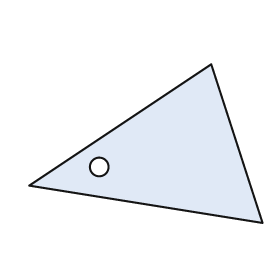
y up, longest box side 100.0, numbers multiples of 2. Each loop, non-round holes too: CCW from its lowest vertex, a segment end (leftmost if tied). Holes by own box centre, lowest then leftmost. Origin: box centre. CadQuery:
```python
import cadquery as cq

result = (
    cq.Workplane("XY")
    .moveTo(50.0, -34.0)
    .lineTo(28.0, 34.0)
    .lineTo(-50.0, -18.0)
    .close()
    .moveTo(-20.0, -10.0)
    .circle(4.0)
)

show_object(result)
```